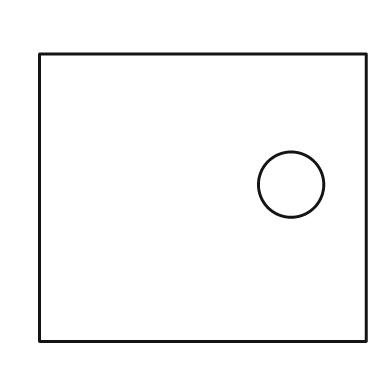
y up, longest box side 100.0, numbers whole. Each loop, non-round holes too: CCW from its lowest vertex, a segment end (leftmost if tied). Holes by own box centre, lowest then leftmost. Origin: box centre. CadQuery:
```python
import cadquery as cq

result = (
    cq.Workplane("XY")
    .moveTo(-50.0, -44.0)
    .lineTo(50.0, -44.0)
    .lineTo(50.0, 44.0)
    .lineTo(-50.0, 44.0)
    .close()
    .moveTo(27.0, 4.0)
    .circle(10.0)
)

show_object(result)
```